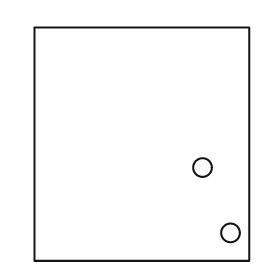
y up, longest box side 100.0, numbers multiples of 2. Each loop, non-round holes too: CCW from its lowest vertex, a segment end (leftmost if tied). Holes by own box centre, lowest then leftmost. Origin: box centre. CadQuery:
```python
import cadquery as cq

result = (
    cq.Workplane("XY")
    .moveTo(-46.0, -50.0)
    .lineTo(46.0, -50.0)
    .lineTo(46.0, 50.0)
    .lineTo(-46.0, 50.0)
    .close()
    .moveTo(38.0, -38.0)
    .circle(4.0)
    .moveTo(26.0, -10.0)
    .circle(4.0)
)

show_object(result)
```